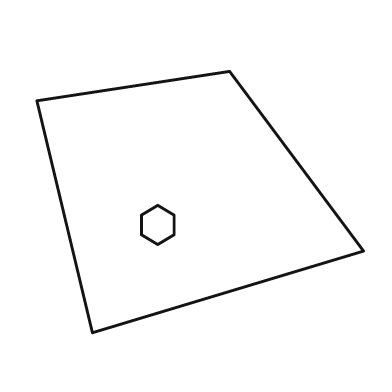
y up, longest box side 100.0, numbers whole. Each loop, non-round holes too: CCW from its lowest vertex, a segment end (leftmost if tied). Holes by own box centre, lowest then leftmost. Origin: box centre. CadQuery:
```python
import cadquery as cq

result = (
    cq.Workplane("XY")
    .moveTo(-33.0, -40.0)
    .lineTo(50.0, -15.0)
    .lineTo(9.0, 40.0)
    .lineTo(-50.0, 31.0)
    .close()
    .moveTo(-13.0, -13.0)
    .lineTo(-8.0, -10.0)
    .lineTo(-8.0, -4.0)
    .lineTo(-13.0, -1.0)
    .lineTo(-18.0, -4.0)
    .lineTo(-18.0, -10.0)
    .close()
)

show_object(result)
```